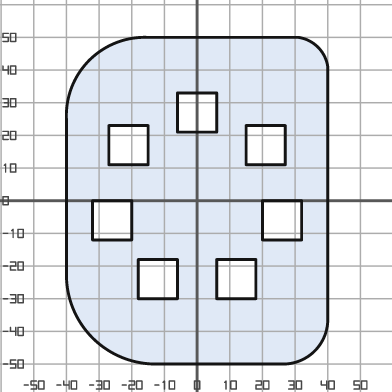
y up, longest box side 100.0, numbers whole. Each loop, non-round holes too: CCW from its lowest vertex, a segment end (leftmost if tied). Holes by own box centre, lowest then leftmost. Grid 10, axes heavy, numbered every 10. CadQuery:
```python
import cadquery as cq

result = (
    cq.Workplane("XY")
    .moveTo(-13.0, -50.0)
    .lineTo(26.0, -50.0)
    .threePointArc((36.0, -46.0), (40.0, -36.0))
    .lineTo(40.0, 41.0)
    .threePointArc((37.0, 47.0), (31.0, 50.0))
    .lineTo(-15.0, 50.0)
    .threePointArc((-33.0, 43.0), (-40.0, 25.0))
    .lineTo(-40.0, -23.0)
    .threePointArc((-32.0, -42.0), (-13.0, -50.0))
    .close()
    .moveTo(-18.0, -30.0)
    .lineTo(-6.0, -30.0)
    .lineTo(-6.0, -18.0)
    .lineTo(-18.0, -18.0)
    .close()
    .moveTo(6.0, -30.0)
    .lineTo(18.0, -30.0)
    .lineTo(18.0, -18.0)
    .lineTo(6.0, -18.0)
    .close()
    .moveTo(-32.0, -12.0)
    .lineTo(-20.0, -12.0)
    .lineTo(-20.0, 0.0)
    .lineTo(-32.0, 0.0)
    .close()
    .moveTo(20.0, -12.0)
    .lineTo(32.0, -12.0)
    .lineTo(32.0, 0.0)
    .lineTo(20.0, 0.0)
    .close()
    .moveTo(-27.0, 11.0)
    .lineTo(-15.0, 11.0)
    .lineTo(-15.0, 23.0)
    .lineTo(-27.0, 23.0)
    .close()
    .moveTo(15.0, 11.0)
    .lineTo(27.0, 11.0)
    .lineTo(27.0, 23.0)
    .lineTo(15.0, 23.0)
    .close()
    .moveTo(-6.0, 21.0)
    .lineTo(6.0, 21.0)
    .lineTo(6.0, 33.0)
    .lineTo(-6.0, 33.0)
    .close()
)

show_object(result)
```